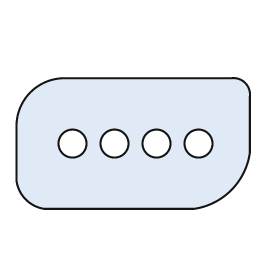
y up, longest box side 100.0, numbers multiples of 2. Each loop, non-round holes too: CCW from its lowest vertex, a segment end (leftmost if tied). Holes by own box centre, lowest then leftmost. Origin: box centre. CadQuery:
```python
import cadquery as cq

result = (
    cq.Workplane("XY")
    .moveTo(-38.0, -28.0)
    .lineTo(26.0, -28.0)
    .threePointArc((42.0, -20.0), (50.0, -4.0))
    .lineTo(50.0, 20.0)
    .threePointArc((48.0, 26.0), (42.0, 28.0))
    .lineTo(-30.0, 28.0)
    .threePointArc((-44.0, 22.0), (-50.0, 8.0))
    .lineTo(-50.0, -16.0)
    .threePointArc((-46.0, -24.0), (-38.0, -28.0))
    .close()
    .moveTo(-26.0, 0.0)
    .circle(6.0)
    .moveTo(-8.0, 0.0)
    .circle(6.0)
    .moveTo(10.0, 0.0)
    .circle(6.0)
    .moveTo(28.0, 0.0)
    .circle(6.0)
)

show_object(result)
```